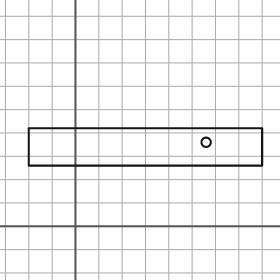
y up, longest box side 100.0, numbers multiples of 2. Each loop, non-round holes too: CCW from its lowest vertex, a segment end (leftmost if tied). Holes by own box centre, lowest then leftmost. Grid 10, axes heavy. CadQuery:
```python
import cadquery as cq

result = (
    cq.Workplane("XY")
    .moveTo(-20.0, 26.0)
    .lineTo(80.0, 26.0)
    .lineTo(80.0, 42.0)
    .lineTo(-20.0, 42.0)
    .close()
    .moveTo(56.0, 36.0)
    .circle(2.0)
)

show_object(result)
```